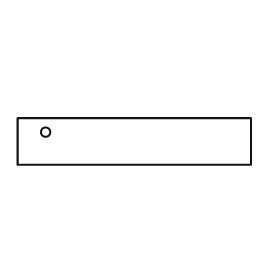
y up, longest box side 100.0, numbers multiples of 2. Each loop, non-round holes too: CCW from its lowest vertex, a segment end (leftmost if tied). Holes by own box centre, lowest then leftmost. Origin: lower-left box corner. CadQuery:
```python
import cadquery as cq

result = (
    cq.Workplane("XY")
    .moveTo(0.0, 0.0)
    .lineTo(100.0, 0.0)
    .lineTo(100.0, 20.0)
    .lineTo(0.0, 20.0)
    .close()
    .moveTo(12.0, 14.0)
    .circle(2.0)
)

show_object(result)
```